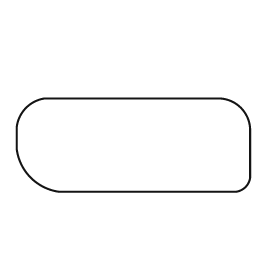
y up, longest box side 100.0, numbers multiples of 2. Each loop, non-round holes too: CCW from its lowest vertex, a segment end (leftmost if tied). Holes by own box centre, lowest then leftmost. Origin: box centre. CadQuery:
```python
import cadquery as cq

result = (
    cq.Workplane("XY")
    .moveTo(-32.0, -20.0)
    .lineTo(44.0, -20.0)
    .threePointArc((48.0, -18.0), (50.0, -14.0))
    .lineTo(50.0, 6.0)
    .threePointArc((46.0, 16.0), (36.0, 20.0))
    .lineTo(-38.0, 20.0)
    .threePointArc((-46.0, 16.0), (-50.0, 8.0))
    .lineTo(-50.0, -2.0)
    .threePointArc((-44.0, -14.0), (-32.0, -20.0))
    .close()
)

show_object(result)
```